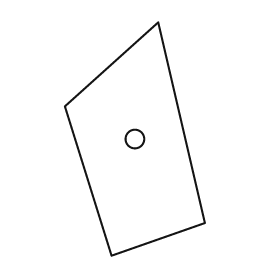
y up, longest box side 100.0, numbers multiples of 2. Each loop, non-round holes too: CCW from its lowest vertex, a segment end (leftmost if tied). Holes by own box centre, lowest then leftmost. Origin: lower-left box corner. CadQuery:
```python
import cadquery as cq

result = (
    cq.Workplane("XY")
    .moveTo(20.0, 0.0)
    .lineTo(60.0, 14.0)
    .lineTo(40.0, 100.0)
    .lineTo(0.0, 64.0)
    .close()
    .moveTo(30.0, 50.0)
    .circle(4.0)
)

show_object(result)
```